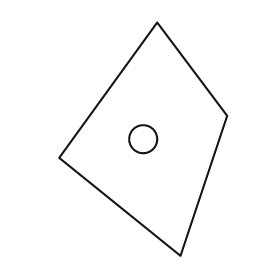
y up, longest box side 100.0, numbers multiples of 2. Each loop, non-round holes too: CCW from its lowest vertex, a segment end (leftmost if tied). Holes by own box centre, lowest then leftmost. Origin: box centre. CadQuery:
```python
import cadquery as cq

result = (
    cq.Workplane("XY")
    .moveTo(16.0, -50.0)
    .lineTo(36.0, 10.0)
    .lineTo(6.0, 50.0)
    .lineTo(-36.0, -8.0)
    .close()
    .moveTo(0.0, 0.0)
    .circle(6.0)
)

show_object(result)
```